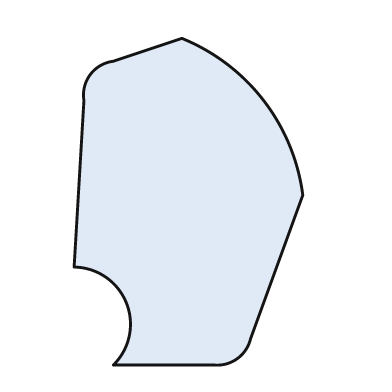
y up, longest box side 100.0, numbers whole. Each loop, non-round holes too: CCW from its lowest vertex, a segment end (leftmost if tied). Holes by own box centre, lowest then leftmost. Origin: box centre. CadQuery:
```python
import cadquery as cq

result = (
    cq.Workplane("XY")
    .moveTo(-23.0, -50.0)
    .lineTo(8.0, -50.0)
    .threePointArc((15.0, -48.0), (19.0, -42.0))
    .lineTo(35.0, 2.0)
    .threePointArc((23.0, 31.0), (-2.0, 50.0))
    .lineTo(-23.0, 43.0)
    .threePointArc((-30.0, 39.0), (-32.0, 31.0))
    .lineTo(-35.0, -20.0)
    .threePointArc((-19.0, -31.0), (-23.0, -50.0))
    .close()
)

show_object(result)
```